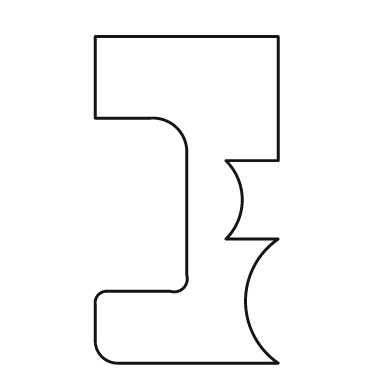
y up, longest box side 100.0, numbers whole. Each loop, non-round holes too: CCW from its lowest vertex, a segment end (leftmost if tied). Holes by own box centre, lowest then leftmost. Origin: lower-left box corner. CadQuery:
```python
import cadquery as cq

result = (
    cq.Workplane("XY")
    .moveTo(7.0, 0.0)
    .lineTo(56.0, 0.0)
    .threePointArc((46.0, 19.0), (56.0, 38.0))
    .lineTo(40.0, 38.0)
    .threePointArc((45.0, 50.0), (40.0, 62.0))
    .lineTo(56.0, 62.0)
    .lineTo(56.0, 100.0)
    .lineTo(0.0, 100.0)
    .lineTo(0.0, 75.0)
    .lineTo(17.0, 75.0)
    .threePointArc((25.0, 72.0), (28.0, 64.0))
    .lineTo(28.0, 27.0)
    .threePointArc((27.0, 23.0), (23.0, 22.0))
    .lineTo(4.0, 22.0)
    .threePointArc((1.0, 21.0), (0.0, 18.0))
    .lineTo(0.0, 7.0)
    .threePointArc((2.0, 2.0), (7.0, 0.0))
    .close()
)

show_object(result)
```